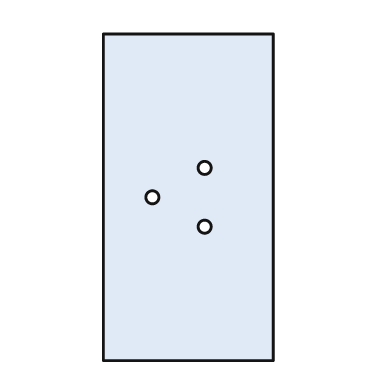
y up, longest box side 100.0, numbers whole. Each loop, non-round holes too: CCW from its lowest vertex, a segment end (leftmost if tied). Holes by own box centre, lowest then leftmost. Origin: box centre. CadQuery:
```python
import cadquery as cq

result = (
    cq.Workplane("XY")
    .moveTo(-26.0, -50.0)
    .lineTo(26.0, -50.0)
    .lineTo(26.0, 50.0)
    .lineTo(-26.0, 50.0)
    .close()
    .moveTo(5.0, -9.0)
    .circle(2.0)
    .moveTo(-11.0, 0.0)
    .circle(2.0)
    .moveTo(5.0, 9.0)
    .circle(2.0)
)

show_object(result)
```